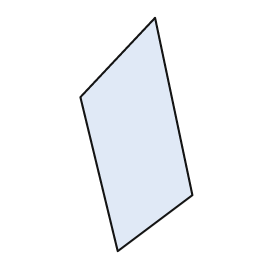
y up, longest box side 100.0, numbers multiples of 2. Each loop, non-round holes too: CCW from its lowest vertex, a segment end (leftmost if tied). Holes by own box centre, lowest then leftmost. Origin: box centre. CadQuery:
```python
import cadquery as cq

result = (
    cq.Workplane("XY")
    .moveTo(-8.0, -50.0)
    .lineTo(24.0, -26.0)
    .lineTo(8.0, 50.0)
    .lineTo(-24.0, 16.0)
    .close()
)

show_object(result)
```